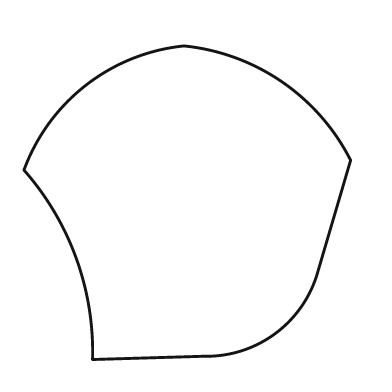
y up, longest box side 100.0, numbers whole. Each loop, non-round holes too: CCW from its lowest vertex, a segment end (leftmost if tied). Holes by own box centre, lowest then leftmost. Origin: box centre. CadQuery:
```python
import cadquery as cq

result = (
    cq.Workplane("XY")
    .moveTo(-29.0, -48.0)
    .lineTo(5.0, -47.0)
    .threePointArc((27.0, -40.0), (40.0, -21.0))
    .lineTo(50.0, 13.0)
    .threePointArc((29.0, 37.0), (-1.0, 48.0))
    .threePointArc((-31.0, 36.0), (-50.0, 10.0))
    .threePointArc((-34.0, -17.0), (-29.0, -48.0))
    .close()
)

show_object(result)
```